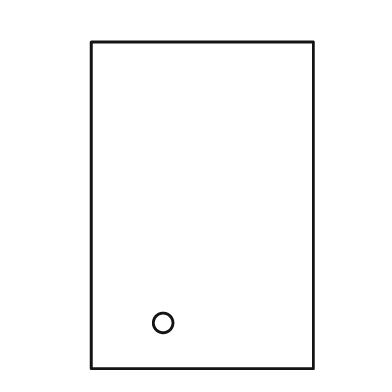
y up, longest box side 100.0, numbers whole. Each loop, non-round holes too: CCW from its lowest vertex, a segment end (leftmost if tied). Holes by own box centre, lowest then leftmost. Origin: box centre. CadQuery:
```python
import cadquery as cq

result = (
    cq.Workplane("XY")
    .moveTo(-34.0, -50.0)
    .lineTo(34.0, -50.0)
    .lineTo(34.0, 50.0)
    .lineTo(-34.0, 50.0)
    .close()
    .moveTo(-12.0, -36.0)
    .circle(3.0)
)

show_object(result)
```